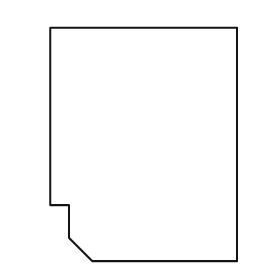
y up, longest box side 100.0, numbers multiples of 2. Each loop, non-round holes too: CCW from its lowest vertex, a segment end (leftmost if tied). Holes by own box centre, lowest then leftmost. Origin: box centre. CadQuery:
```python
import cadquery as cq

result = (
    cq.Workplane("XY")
    .moveTo(-22.0, -50.0)
    .lineTo(40.0, -50.0)
    .lineTo(40.0, 50.0)
    .lineTo(-40.0, 50.0)
    .lineTo(-40.0, -26.0)
    .lineTo(-32.0, -26.0)
    .lineTo(-32.0, -40.0)
    .close()
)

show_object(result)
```